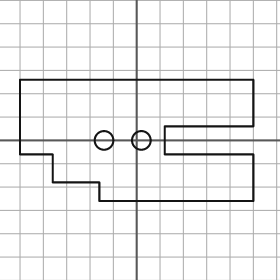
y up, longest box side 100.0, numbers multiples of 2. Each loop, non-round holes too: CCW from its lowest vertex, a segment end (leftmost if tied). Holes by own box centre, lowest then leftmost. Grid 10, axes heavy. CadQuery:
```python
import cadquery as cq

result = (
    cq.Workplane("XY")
    .moveTo(-16.0, -26.0)
    .lineTo(50.0, -26.0)
    .lineTo(50.0, -6.0)
    .lineTo(12.0, -6.0)
    .lineTo(12.0, 6.0)
    .lineTo(50.0, 6.0)
    .lineTo(50.0, 26.0)
    .lineTo(-50.0, 26.0)
    .lineTo(-50.0, -6.0)
    .lineTo(-36.0, -6.0)
    .lineTo(-36.0, -18.0)
    .lineTo(-16.0, -18.0)
    .close()
    .moveTo(-14.0, 0.0)
    .circle(4.0)
    .moveTo(2.0, 0.0)
    .circle(4.0)
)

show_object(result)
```